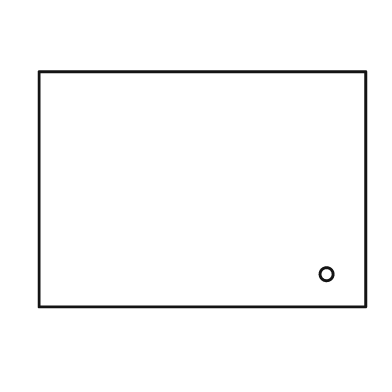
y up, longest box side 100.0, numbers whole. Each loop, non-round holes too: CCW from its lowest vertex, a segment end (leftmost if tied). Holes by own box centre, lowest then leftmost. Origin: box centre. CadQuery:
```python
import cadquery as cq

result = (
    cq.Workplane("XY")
    .moveTo(-50.0, -36.0)
    .lineTo(50.0, -36.0)
    .lineTo(50.0, 36.0)
    .lineTo(-50.0, 36.0)
    .close()
    .moveTo(38.0, -26.0)
    .circle(2.0)
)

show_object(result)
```